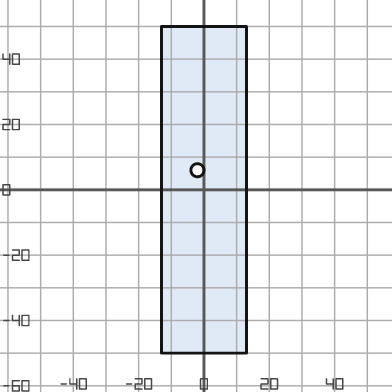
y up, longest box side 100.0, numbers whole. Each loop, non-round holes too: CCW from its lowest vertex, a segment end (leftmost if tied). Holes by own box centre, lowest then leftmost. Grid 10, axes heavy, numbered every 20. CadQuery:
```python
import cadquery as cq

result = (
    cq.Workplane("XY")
    .moveTo(-13.0, -50.0)
    .lineTo(13.0, -50.0)
    .lineTo(13.0, 50.0)
    .lineTo(-13.0, 50.0)
    .close()
    .moveTo(-2.0, 6.0)
    .circle(2.0)
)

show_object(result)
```